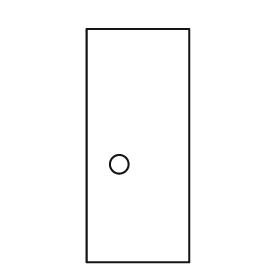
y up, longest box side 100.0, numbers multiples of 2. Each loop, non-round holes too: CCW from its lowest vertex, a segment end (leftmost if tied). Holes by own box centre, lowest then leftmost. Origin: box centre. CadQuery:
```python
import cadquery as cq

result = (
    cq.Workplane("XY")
    .moveTo(-22.0, -50.0)
    .lineTo(22.0, -50.0)
    .lineTo(22.0, 50.0)
    .lineTo(-22.0, 50.0)
    .close()
    .moveTo(-8.0, -8.0)
    .circle(4.0)
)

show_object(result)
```